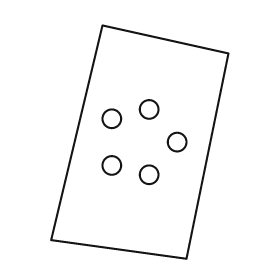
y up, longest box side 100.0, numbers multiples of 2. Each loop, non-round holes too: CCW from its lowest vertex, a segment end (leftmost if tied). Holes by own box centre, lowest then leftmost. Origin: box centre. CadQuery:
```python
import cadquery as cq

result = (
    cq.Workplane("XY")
    .moveTo(20.0, -50.0)
    .lineTo(38.0, 38.0)
    .lineTo(-16.0, 50.0)
    .lineTo(-38.0, -42.0)
    .close()
    .moveTo(4.0, -14.0)
    .circle(4.0)
    .moveTo(-12.0, -10.0)
    .circle(4.0)
    .moveTo(16.0, 0.0)
    .circle(4.0)
    .moveTo(-12.0, 10.0)
    .circle(4.0)
    .moveTo(4.0, 14.0)
    .circle(4.0)
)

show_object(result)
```